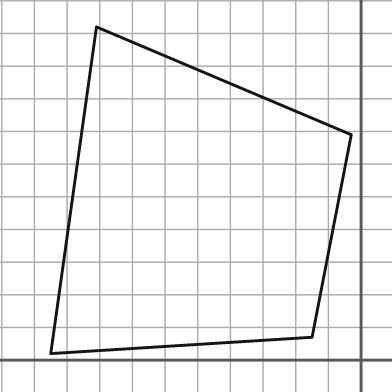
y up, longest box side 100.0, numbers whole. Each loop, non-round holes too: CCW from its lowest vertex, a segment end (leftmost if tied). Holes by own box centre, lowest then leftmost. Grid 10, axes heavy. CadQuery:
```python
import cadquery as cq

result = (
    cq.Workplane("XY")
    .moveTo(-95.0, 2.0)
    .lineTo(-15.0, 7.0)
    .lineTo(-3.0, 69.0)
    .lineTo(-81.0, 102.0)
    .close()
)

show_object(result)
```